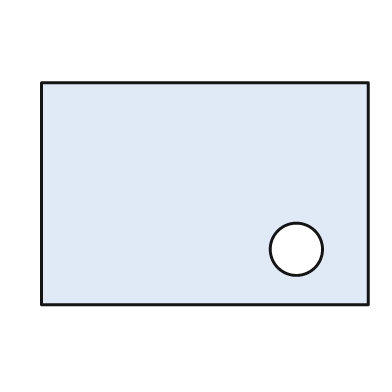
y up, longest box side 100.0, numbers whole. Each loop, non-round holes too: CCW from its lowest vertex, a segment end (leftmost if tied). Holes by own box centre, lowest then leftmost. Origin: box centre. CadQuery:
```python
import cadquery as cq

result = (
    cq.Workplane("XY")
    .moveTo(-50.0, -34.0)
    .lineTo(50.0, -34.0)
    .lineTo(50.0, 34.0)
    .lineTo(-50.0, 34.0)
    .close()
    .moveTo(28.0, -17.0)
    .circle(8.0)
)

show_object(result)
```